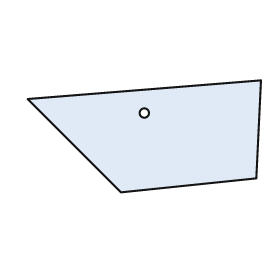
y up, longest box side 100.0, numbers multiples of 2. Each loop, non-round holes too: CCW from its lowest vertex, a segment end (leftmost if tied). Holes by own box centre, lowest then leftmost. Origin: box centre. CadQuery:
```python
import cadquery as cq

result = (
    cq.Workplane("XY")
    .moveTo(-10.0, -24.0)
    .lineTo(48.0, -18.0)
    .lineTo(50.0, 24.0)
    .lineTo(-50.0, 16.0)
    .close()
    .moveTo(0.0, 10.0)
    .circle(2.0)
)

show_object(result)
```